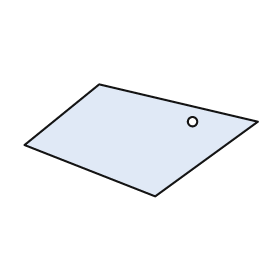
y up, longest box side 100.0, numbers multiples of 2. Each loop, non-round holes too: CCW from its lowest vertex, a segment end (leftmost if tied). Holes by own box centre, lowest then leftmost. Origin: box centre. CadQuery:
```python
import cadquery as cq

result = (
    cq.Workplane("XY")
    .moveTo(6.0, -24.0)
    .lineTo(50.0, 8.0)
    .lineTo(-18.0, 24.0)
    .lineTo(-50.0, -2.0)
    .close()
    .moveTo(22.0, 8.0)
    .circle(2.0)
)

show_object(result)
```